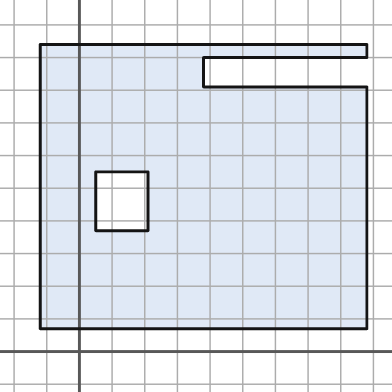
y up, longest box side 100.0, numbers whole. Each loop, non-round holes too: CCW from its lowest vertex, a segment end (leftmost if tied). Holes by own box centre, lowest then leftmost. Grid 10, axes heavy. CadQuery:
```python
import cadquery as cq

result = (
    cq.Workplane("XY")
    .moveTo(-12.0, 7.0)
    .lineTo(88.0, 7.0)
    .lineTo(88.0, 81.0)
    .lineTo(38.0, 81.0)
    .lineTo(38.0, 90.0)
    .lineTo(88.0, 90.0)
    .lineTo(88.0, 94.0)
    .lineTo(-12.0, 94.0)
    .close()
    .moveTo(5.0, 37.0)
    .lineTo(21.0, 37.0)
    .lineTo(21.0, 55.0)
    .lineTo(5.0, 55.0)
    .close()
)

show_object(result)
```